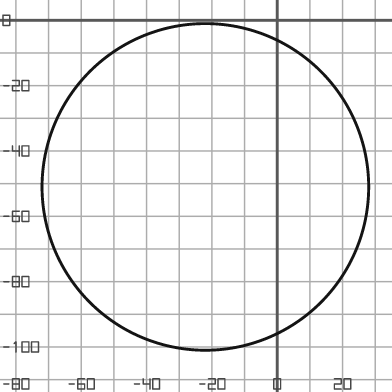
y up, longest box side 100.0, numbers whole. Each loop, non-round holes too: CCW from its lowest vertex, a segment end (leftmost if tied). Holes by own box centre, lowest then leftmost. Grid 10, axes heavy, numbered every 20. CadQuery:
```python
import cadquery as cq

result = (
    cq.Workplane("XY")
    .moveTo(-22.0, -51.0)
    .circle(50.0)
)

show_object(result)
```